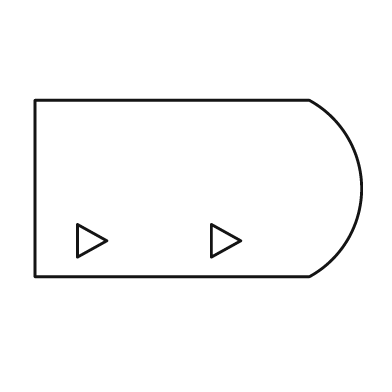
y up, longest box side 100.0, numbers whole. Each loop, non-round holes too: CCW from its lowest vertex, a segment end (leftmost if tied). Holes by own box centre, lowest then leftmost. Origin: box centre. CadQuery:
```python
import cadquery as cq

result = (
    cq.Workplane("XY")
    .moveTo(-50.0, -27.0)
    .lineTo(34.0, -27.0)
    .threePointArc((50.0, 0.0), (34.0, 27.0))
    .lineTo(-50.0, 27.0)
    .close()
    .moveTo(-37.0, -21.0)
    .lineTo(-28.0, -16.0)
    .lineTo(-37.0, -11.0)
    .close()
    .moveTo(4.0, -21.0)
    .lineTo(13.0, -16.0)
    .lineTo(4.0, -11.0)
    .close()
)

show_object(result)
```